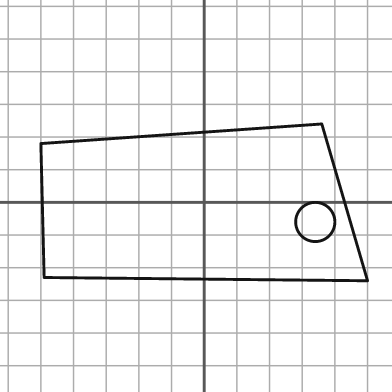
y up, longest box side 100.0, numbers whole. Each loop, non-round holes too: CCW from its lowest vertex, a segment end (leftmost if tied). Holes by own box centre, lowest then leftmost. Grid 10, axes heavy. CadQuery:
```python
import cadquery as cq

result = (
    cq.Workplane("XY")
    .moveTo(50.0, -24.0)
    .lineTo(36.0, 24.0)
    .lineTo(-50.0, 18.0)
    .lineTo(-49.0, -23.0)
    .close()
    .moveTo(34.0, -6.0)
    .circle(6.0)
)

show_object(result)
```